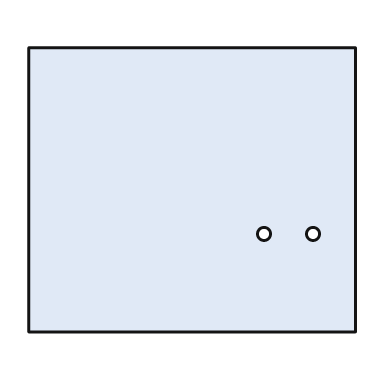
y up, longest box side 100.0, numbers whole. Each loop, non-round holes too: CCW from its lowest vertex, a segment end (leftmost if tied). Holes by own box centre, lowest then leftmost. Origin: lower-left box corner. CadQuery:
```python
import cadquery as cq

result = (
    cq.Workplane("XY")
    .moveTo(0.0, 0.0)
    .lineTo(100.0, 0.0)
    .lineTo(100.0, 87.0)
    .lineTo(0.0, 87.0)
    .close()
    .moveTo(72.0, 30.0)
    .circle(2.0)
    .moveTo(87.0, 30.0)
    .circle(2.0)
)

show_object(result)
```